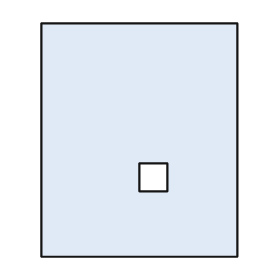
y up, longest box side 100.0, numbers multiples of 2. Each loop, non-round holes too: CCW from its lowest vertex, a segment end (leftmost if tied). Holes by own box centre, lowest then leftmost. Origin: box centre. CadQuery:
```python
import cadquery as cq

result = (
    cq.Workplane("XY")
    .moveTo(-42.0, -50.0)
    .lineTo(42.0, -50.0)
    .lineTo(42.0, 50.0)
    .lineTo(-42.0, 50.0)
    .close()
    .moveTo(0.0, -22.0)
    .lineTo(12.0, -22.0)
    .lineTo(12.0, -10.0)
    .lineTo(0.0, -10.0)
    .close()
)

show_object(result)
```